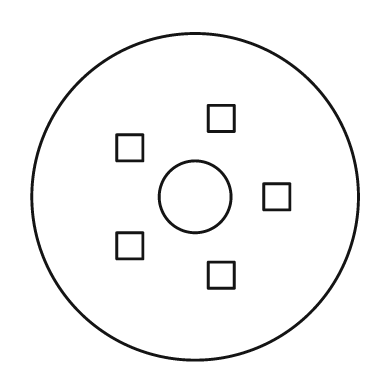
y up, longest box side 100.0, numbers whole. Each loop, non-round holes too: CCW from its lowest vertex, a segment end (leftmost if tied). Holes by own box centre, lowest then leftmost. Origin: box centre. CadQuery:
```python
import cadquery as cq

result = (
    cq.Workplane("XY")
    .moveTo(0.0, 0.0)
    .circle(50.0)
    .moveTo(4.0, -28.0)
    .lineTo(12.0, -28.0)
    .lineTo(12.0, -20.0)
    .lineTo(4.0, -20.0)
    .close()
    .moveTo(-24.0, -19.0)
    .lineTo(-16.0, -19.0)
    .lineTo(-16.0, -11.0)
    .lineTo(-24.0, -11.0)
    .close()
    .moveTo(0.0, 0.0)
    .circle(11.0)
    .moveTo(21.0, -4.0)
    .lineTo(29.0, -4.0)
    .lineTo(29.0, 4.0)
    .lineTo(21.0, 4.0)
    .close()
    .moveTo(-24.0, 11.0)
    .lineTo(-16.0, 11.0)
    .lineTo(-16.0, 19.0)
    .lineTo(-24.0, 19.0)
    .close()
    .moveTo(4.0, 20.0)
    .lineTo(12.0, 20.0)
    .lineTo(12.0, 28.0)
    .lineTo(4.0, 28.0)
    .close()
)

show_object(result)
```